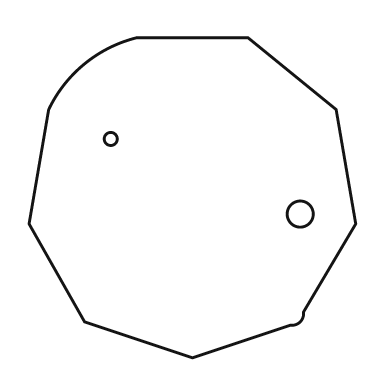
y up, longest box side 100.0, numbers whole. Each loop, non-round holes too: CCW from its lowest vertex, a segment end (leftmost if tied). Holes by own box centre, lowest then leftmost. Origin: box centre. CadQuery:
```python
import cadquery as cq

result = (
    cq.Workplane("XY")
    .moveTo(0.0, -49.0)
    .lineTo(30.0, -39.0)
    .threePointArc((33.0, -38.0), (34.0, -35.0))
    .lineTo(50.0, -8.0)
    .lineTo(44.0, 27.0)
    .lineTo(17.0, 49.0)
    .lineTo(-17.0, 49.0)
    .threePointArc((-33.0, 41.0), (-44.0, 27.0))
    .lineTo(-50.0, -8.0)
    .lineTo(-33.0, -38.0)
    .close()
    .moveTo(33.0, -5.0)
    .circle(4.0)
    .moveTo(-25.0, 18.0)
    .circle(2.0)
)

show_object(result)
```